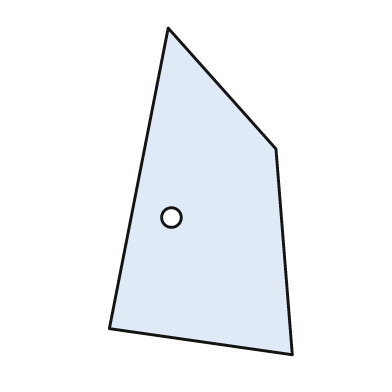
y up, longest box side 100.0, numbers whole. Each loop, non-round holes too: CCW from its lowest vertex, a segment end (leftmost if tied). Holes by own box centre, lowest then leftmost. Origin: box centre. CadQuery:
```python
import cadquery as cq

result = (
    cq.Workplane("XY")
    .moveTo(28.0, -50.0)
    .lineTo(23.0, 13.0)
    .lineTo(-10.0, 50.0)
    .lineTo(-28.0, -42.0)
    .close()
    .moveTo(-9.0, -8.0)
    .circle(3.0)
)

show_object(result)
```